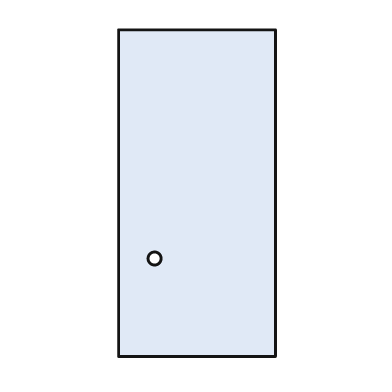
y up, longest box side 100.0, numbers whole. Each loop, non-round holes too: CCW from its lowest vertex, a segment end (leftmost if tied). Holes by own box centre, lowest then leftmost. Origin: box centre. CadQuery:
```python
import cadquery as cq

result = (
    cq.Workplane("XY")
    .moveTo(-24.0, -50.0)
    .lineTo(24.0, -50.0)
    .lineTo(24.0, 50.0)
    .lineTo(-24.0, 50.0)
    .close()
    .moveTo(-13.0, -20.0)
    .circle(2.0)
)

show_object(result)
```